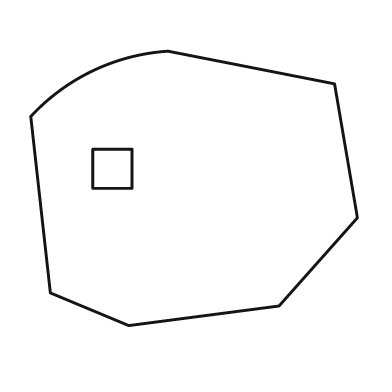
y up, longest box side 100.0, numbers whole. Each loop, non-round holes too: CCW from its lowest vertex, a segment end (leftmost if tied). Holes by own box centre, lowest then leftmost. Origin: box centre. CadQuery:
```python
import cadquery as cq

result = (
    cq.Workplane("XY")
    .moveTo(-20.0, -42.0)
    .lineTo(26.0, -36.0)
    .lineTo(50.0, -9.0)
    .lineTo(43.0, 32.0)
    .lineTo(-8.0, 42.0)
    .threePointArc((-31.0, 36.0), (-50.0, 22.0))
    .lineTo(-44.0, -32.0)
    .close()
    .moveTo(-31.0, 0.0)
    .lineTo(-19.0, 0.0)
    .lineTo(-19.0, 12.0)
    .lineTo(-31.0, 12.0)
    .close()
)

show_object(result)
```